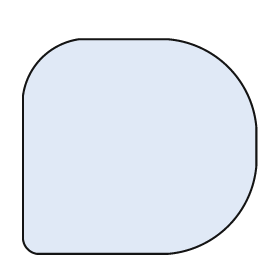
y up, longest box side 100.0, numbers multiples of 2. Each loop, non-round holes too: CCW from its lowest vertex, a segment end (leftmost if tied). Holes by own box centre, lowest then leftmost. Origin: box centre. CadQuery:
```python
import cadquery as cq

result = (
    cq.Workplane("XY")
    .moveTo(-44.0, -46.0)
    .lineTo(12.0, -46.0)
    .threePointArc((38.0, -34.0), (50.0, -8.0))
    .lineTo(50.0, 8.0)
    .threePointArc((38.0, 34.0), (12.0, 46.0))
    .lineTo(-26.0, 46.0)
    .threePointArc((-42.0, 38.0), (-50.0, 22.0))
    .lineTo(-50.0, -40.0)
    .threePointArc((-48.0, -44.0), (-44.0, -46.0))
    .close()
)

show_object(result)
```